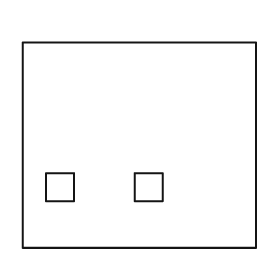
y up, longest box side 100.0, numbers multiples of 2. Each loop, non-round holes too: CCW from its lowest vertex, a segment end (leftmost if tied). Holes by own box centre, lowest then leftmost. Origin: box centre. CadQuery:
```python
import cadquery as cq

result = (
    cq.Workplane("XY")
    .moveTo(-50.0, -44.0)
    .lineTo(50.0, -44.0)
    .lineTo(50.0, 44.0)
    .lineTo(-50.0, 44.0)
    .close()
    .moveTo(-40.0, -24.0)
    .lineTo(-28.0, -24.0)
    .lineTo(-28.0, -12.0)
    .lineTo(-40.0, -12.0)
    .close()
    .moveTo(-2.0, -24.0)
    .lineTo(10.0, -24.0)
    .lineTo(10.0, -12.0)
    .lineTo(-2.0, -12.0)
    .close()
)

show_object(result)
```